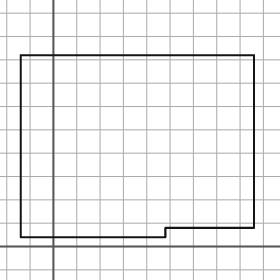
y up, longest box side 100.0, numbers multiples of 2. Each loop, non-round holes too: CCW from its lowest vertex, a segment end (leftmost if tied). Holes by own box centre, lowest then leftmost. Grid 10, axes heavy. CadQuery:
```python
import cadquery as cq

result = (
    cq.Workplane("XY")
    .moveTo(-14.0, 4.0)
    .lineTo(48.0, 4.0)
    .lineTo(48.0, 8.0)
    .lineTo(86.0, 8.0)
    .lineTo(86.0, 82.0)
    .lineTo(-14.0, 82.0)
    .close()
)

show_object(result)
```